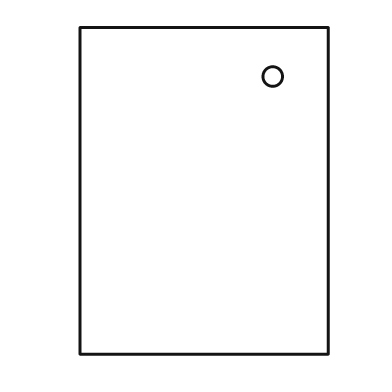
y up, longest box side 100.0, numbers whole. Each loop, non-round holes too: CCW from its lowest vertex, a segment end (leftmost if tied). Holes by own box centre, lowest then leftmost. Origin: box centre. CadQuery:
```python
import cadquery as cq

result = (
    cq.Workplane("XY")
    .moveTo(-38.0, -50.0)
    .lineTo(38.0, -50.0)
    .lineTo(38.0, 50.0)
    .lineTo(-38.0, 50.0)
    .close()
    .moveTo(21.0, 35.0)
    .circle(3.0)
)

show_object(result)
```